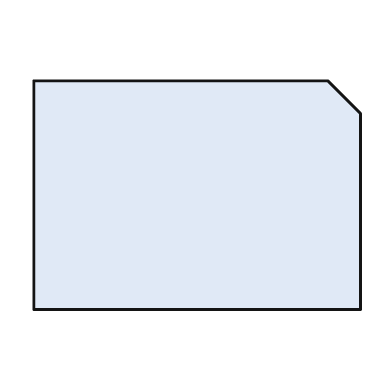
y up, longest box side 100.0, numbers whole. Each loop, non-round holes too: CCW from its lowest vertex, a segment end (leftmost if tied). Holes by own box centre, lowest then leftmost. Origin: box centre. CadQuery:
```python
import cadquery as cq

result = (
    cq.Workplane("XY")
    .moveTo(-50.0, -35.0)
    .lineTo(50.0, -35.0)
    .lineTo(50.0, 25.0)
    .lineTo(40.0, 35.0)
    .lineTo(-50.0, 35.0)
    .close()
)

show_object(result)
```